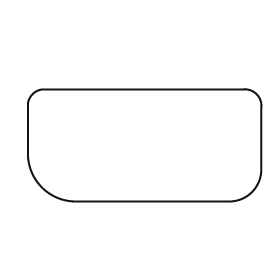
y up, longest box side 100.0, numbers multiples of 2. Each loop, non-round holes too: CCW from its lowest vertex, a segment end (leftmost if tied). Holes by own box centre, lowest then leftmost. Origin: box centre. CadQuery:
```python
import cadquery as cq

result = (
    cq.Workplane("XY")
    .moveTo(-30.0, -24.0)
    .lineTo(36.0, -24.0)
    .threePointArc((46.0, -20.0), (50.0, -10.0))
    .lineTo(50.0, 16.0)
    .threePointArc((48.0, 22.0), (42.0, 24.0))
    .lineTo(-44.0, 24.0)
    .threePointArc((-48.0, 22.0), (-50.0, 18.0))
    .lineTo(-50.0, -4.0)
    .threePointArc((-44.0, -18.0), (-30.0, -24.0))
    .close()
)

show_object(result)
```